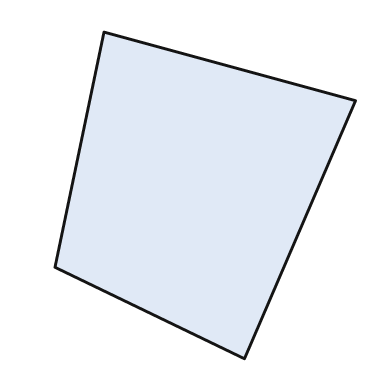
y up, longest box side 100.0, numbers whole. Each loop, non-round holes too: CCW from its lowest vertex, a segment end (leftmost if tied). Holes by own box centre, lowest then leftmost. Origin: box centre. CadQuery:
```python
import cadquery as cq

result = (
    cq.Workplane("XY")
    .moveTo(12.0, -50.0)
    .lineTo(46.0, 29.0)
    .lineTo(-31.0, 50.0)
    .lineTo(-46.0, -22.0)
    .close()
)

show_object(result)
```